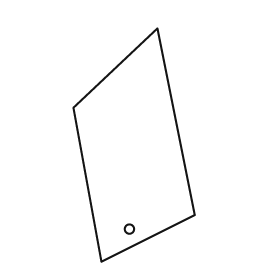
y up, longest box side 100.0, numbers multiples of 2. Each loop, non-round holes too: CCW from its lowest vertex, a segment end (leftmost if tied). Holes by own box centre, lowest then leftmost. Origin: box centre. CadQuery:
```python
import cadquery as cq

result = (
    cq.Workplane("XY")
    .moveTo(-14.0, -50.0)
    .lineTo(26.0, -30.0)
    .lineTo(10.0, 50.0)
    .lineTo(-26.0, 16.0)
    .close()
    .moveTo(-2.0, -36.0)
    .circle(2.0)
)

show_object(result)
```